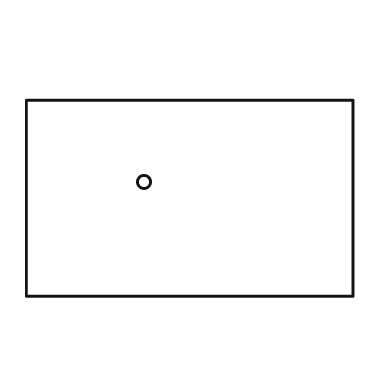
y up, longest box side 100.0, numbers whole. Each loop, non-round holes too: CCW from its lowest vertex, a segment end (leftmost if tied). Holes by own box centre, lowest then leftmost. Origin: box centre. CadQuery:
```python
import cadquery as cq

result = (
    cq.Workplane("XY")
    .moveTo(-50.0, -30.0)
    .lineTo(50.0, -30.0)
    .lineTo(50.0, 30.0)
    .lineTo(-50.0, 30.0)
    .close()
    .moveTo(-14.0, 5.0)
    .circle(2.0)
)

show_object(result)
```